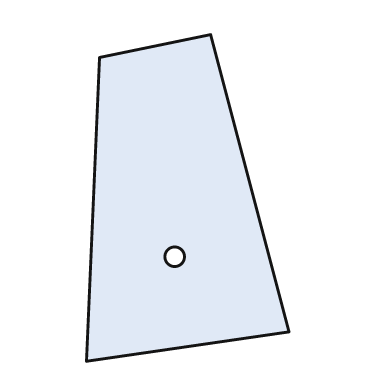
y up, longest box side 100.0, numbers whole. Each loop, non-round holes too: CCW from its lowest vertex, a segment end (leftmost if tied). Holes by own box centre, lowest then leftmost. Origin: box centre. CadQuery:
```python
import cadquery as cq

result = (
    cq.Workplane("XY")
    .moveTo(-31.0, -50.0)
    .lineTo(31.0, -41.0)
    .lineTo(7.0, 50.0)
    .lineTo(-27.0, 43.0)
    .close()
    .moveTo(-4.0, -18.0)
    .circle(3.0)
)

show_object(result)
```